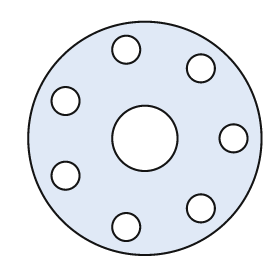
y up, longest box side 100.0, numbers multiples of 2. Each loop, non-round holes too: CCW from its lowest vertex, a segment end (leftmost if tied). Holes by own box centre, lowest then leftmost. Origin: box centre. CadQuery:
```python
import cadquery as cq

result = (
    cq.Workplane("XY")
    .moveTo(0.0, 0.0)
    .circle(50.0)
    .moveTo(-8.0, -38.0)
    .circle(6.0)
    .moveTo(24.0, -30.0)
    .circle(6.0)
    .moveTo(-34.0, -16.0)
    .circle(6.0)
    .moveTo(0.0, 0.0)
    .circle(14.0)
    .moveTo(38.0, 0.0)
    .circle(6.0)
    .moveTo(-34.0, 16.0)
    .circle(6.0)
    .moveTo(24.0, 30.0)
    .circle(6.0)
    .moveTo(-8.0, 38.0)
    .circle(6.0)
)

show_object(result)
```